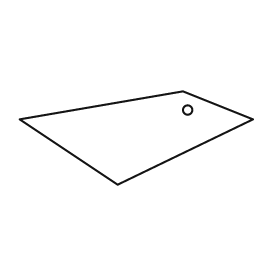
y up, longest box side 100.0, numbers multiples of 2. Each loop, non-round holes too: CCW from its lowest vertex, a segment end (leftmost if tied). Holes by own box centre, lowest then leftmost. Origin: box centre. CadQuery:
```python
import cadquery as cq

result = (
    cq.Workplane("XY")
    .moveTo(-8.0, -20.0)
    .lineTo(50.0, 8.0)
    .lineTo(20.0, 20.0)
    .lineTo(-50.0, 8.0)
    .close()
    .moveTo(22.0, 12.0)
    .circle(2.0)
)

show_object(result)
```